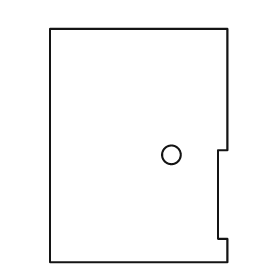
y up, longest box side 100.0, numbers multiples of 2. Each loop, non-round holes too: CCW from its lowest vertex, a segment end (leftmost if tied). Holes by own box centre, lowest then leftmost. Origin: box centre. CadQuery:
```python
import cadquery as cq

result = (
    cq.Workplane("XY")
    .moveTo(-38.0, -50.0)
    .lineTo(38.0, -50.0)
    .lineTo(38.0, -40.0)
    .lineTo(34.0, -40.0)
    .lineTo(34.0, -2.0)
    .lineTo(38.0, -2.0)
    .lineTo(38.0, 50.0)
    .lineTo(-38.0, 50.0)
    .close()
    .moveTo(14.0, -4.0)
    .circle(4.0)
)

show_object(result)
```